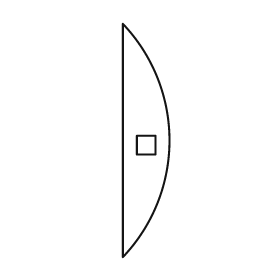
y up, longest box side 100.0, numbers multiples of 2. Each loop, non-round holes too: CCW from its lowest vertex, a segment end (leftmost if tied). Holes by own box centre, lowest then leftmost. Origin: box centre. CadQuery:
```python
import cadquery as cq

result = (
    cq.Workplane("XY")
    .moveTo(-10.0, -50.0)
    .threePointArc((10.0, 0.0), (-10.0, 50.0))
    .close()
    .moveTo(-4.0, -6.0)
    .lineTo(4.0, -6.0)
    .lineTo(4.0, 2.0)
    .lineTo(-4.0, 2.0)
    .close()
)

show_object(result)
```